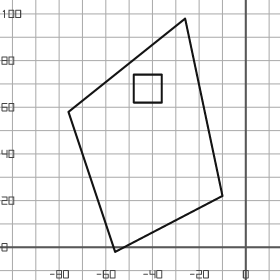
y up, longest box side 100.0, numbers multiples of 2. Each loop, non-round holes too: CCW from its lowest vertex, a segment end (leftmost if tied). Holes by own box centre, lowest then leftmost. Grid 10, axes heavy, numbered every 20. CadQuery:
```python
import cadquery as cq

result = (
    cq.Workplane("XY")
    .moveTo(-56.0, -2.0)
    .lineTo(-10.0, 22.0)
    .lineTo(-26.0, 98.0)
    .lineTo(-76.0, 58.0)
    .close()
    .moveTo(-48.0, 62.0)
    .lineTo(-36.0, 62.0)
    .lineTo(-36.0, 74.0)
    .lineTo(-48.0, 74.0)
    .close()
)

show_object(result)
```